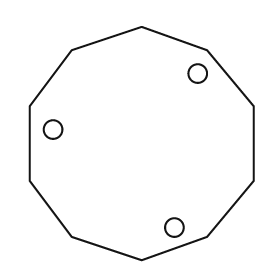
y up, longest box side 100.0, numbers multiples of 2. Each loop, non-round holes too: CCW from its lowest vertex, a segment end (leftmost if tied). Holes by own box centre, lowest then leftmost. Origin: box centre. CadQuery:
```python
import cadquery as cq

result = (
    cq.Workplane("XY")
    .moveTo(0.0, -50.0)
    .lineTo(28.0, -40.0)
    .lineTo(48.0, -16.0)
    .lineTo(48.0, 16.0)
    .lineTo(28.0, 40.0)
    .lineTo(0.0, 50.0)
    .lineTo(-30.0, 40.0)
    .lineTo(-48.0, 16.0)
    .lineTo(-48.0, -16.0)
    .lineTo(-30.0, -40.0)
    .close()
    .moveTo(14.0, -36.0)
    .circle(4.0)
    .moveTo(-38.0, 6.0)
    .circle(4.0)
    .moveTo(24.0, 30.0)
    .circle(4.0)
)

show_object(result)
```